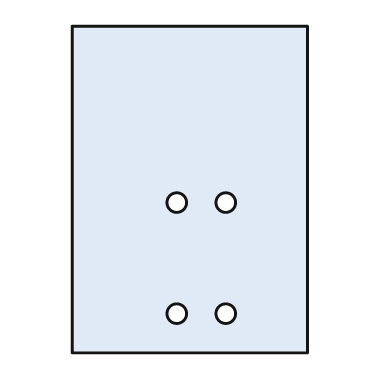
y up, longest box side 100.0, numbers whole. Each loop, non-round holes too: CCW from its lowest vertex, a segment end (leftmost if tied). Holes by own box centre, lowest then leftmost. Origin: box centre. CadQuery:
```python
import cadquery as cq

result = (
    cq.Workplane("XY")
    .moveTo(-36.0, -50.0)
    .lineTo(36.0, -50.0)
    .lineTo(36.0, 50.0)
    .lineTo(-36.0, 50.0)
    .close()
    .moveTo(-4.0, -38.0)
    .circle(3.0)
    .moveTo(11.0, -38.0)
    .circle(3.0)
    .moveTo(-4.0, -4.0)
    .circle(3.0)
    .moveTo(11.0, -4.0)
    .circle(3.0)
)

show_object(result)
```